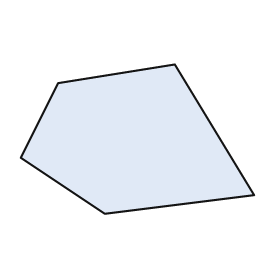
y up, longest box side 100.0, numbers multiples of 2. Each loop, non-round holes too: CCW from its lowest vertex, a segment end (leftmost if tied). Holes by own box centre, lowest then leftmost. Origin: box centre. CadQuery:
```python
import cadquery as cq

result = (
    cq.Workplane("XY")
    .moveTo(-14.0, -32.0)
    .lineTo(50.0, -24.0)
    .lineTo(16.0, 32.0)
    .lineTo(-34.0, 24.0)
    .lineTo(-50.0, -8.0)
    .close()
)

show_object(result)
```